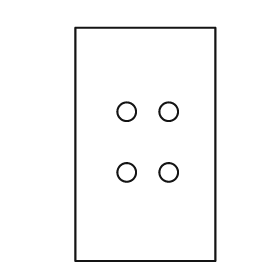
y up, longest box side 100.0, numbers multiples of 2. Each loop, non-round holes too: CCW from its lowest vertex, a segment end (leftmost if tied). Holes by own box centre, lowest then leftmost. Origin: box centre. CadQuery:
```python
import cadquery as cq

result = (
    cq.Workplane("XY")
    .moveTo(-30.0, -50.0)
    .lineTo(30.0, -50.0)
    .lineTo(30.0, 50.0)
    .lineTo(-30.0, 50.0)
    .close()
    .moveTo(-8.0, -12.0)
    .circle(4.0)
    .moveTo(10.0, -12.0)
    .circle(4.0)
    .moveTo(-8.0, 14.0)
    .circle(4.0)
    .moveTo(10.0, 14.0)
    .circle(4.0)
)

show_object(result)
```